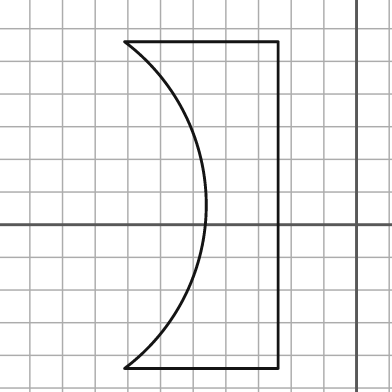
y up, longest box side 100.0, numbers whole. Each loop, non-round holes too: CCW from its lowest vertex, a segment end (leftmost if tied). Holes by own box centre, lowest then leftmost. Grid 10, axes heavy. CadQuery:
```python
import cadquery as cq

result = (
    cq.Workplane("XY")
    .moveTo(-71.0, -44.0)
    .lineTo(-24.0, -44.0)
    .lineTo(-24.0, 56.0)
    .lineTo(-71.0, 56.0)
    .threePointArc((-46.0, 6.0), (-71.0, -44.0))
    .close()
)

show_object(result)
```